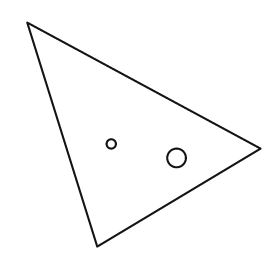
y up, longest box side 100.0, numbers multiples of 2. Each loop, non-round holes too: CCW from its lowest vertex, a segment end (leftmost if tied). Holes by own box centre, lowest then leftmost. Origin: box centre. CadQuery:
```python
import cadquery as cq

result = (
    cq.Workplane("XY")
    .moveTo(-20.0, -48.0)
    .lineTo(50.0, -6.0)
    .lineTo(-50.0, 48.0)
    .close()
    .moveTo(14.0, -10.0)
    .circle(4.0)
    .moveTo(-14.0, -4.0)
    .circle(2.0)
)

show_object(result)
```